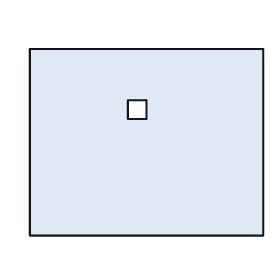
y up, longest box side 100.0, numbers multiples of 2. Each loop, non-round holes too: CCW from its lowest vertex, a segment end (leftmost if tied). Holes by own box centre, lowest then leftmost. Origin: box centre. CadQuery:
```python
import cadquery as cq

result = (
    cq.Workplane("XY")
    .moveTo(-50.0, -40.0)
    .lineTo(50.0, -40.0)
    .lineTo(50.0, 40.0)
    .lineTo(-50.0, 40.0)
    .close()
    .moveTo(-8.0, 10.0)
    .lineTo(0.0, 10.0)
    .lineTo(0.0, 18.0)
    .lineTo(-8.0, 18.0)
    .close()
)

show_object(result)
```